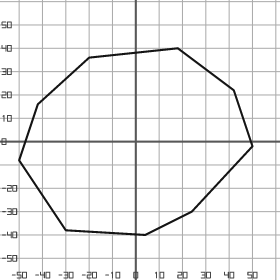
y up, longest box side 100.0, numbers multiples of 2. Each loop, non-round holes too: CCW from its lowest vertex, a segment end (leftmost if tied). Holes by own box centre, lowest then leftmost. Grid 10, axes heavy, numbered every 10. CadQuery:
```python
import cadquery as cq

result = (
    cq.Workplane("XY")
    .moveTo(4.0, -40.0)
    .lineTo(24.0, -30.0)
    .lineTo(50.0, -2.0)
    .lineTo(42.0, 22.0)
    .lineTo(18.0, 40.0)
    .lineTo(-20.0, 36.0)
    .lineTo(-42.0, 16.0)
    .lineTo(-50.0, -8.0)
    .lineTo(-30.0, -38.0)
    .close()
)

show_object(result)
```